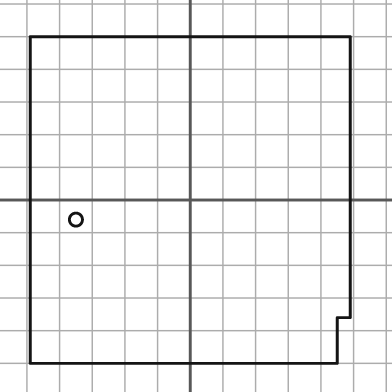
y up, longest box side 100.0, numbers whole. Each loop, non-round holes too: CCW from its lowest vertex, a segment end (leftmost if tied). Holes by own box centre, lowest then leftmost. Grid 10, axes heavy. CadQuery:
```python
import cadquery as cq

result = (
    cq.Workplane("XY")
    .moveTo(-49.0, -50.0)
    .lineTo(45.0, -50.0)
    .lineTo(45.0, -36.0)
    .lineTo(49.0, -36.0)
    .lineTo(49.0, 50.0)
    .lineTo(-49.0, 50.0)
    .close()
    .moveTo(-35.0, -6.0)
    .circle(2.0)
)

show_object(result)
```